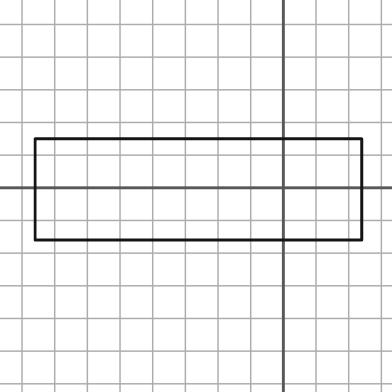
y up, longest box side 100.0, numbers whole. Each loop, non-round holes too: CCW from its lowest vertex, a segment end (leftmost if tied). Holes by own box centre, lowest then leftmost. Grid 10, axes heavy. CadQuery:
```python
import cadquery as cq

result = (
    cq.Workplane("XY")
    .moveTo(-76.0, -16.0)
    .lineTo(24.0, -16.0)
    .lineTo(24.0, 15.0)
    .lineTo(-76.0, 15.0)
    .close()
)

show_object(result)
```